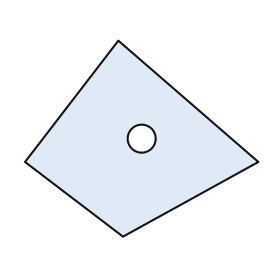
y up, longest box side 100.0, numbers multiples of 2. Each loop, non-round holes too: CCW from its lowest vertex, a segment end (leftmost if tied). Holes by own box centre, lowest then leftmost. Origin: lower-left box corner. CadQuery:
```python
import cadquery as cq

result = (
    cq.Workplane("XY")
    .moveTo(42.0, 0.0)
    .lineTo(100.0, 32.0)
    .lineTo(40.0, 84.0)
    .lineTo(0.0, 32.0)
    .close()
    .moveTo(50.0, 42.0)
    .circle(6.0)
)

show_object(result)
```